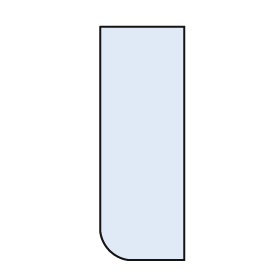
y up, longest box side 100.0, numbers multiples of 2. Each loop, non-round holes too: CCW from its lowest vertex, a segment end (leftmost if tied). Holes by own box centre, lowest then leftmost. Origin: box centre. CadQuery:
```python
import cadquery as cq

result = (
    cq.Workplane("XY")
    .moveTo(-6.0, -50.0)
    .lineTo(18.0, -50.0)
    .lineTo(18.0, 50.0)
    .lineTo(-18.0, 50.0)
    .lineTo(-18.0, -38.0)
    .threePointArc((-14.0, -46.0), (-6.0, -50.0))
    .close()
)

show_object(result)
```